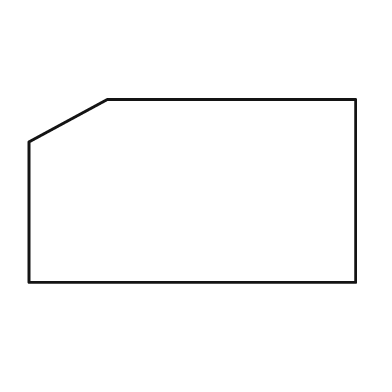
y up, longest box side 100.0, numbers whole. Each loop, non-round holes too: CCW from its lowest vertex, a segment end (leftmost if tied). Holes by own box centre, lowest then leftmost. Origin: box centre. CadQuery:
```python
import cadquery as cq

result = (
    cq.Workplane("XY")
    .moveTo(-50.0, -28.0)
    .lineTo(50.0, -28.0)
    .lineTo(50.0, 28.0)
    .lineTo(-26.0, 28.0)
    .lineTo(-50.0, 15.0)
    .close()
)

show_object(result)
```